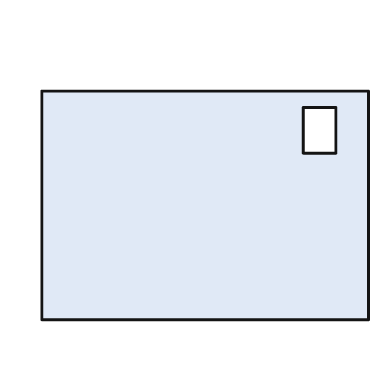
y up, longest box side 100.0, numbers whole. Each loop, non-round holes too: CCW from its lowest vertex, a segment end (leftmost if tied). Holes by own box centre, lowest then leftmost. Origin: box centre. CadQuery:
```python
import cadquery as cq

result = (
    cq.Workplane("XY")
    .moveTo(-50.0, -35.0)
    .lineTo(50.0, -35.0)
    .lineTo(50.0, 35.0)
    .lineTo(-50.0, 35.0)
    .close()
    .moveTo(30.0, 16.0)
    .lineTo(40.0, 16.0)
    .lineTo(40.0, 30.0)
    .lineTo(30.0, 30.0)
    .close()
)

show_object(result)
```